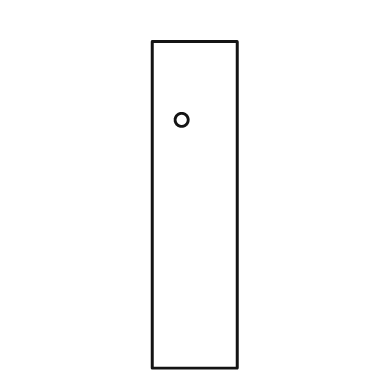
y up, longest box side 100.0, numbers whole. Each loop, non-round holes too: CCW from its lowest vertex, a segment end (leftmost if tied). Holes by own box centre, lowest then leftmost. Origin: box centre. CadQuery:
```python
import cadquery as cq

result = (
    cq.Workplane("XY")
    .moveTo(-13.0, -50.0)
    .lineTo(13.0, -50.0)
    .lineTo(13.0, 50.0)
    .lineTo(-13.0, 50.0)
    .close()
    .moveTo(-4.0, 26.0)
    .circle(2.0)
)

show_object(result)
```